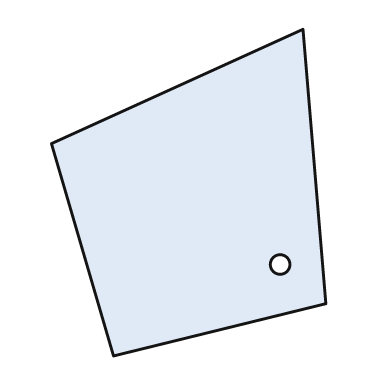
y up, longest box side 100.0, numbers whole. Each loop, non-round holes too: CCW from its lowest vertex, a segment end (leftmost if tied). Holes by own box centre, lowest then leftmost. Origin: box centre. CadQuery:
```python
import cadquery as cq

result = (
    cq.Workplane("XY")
    .moveTo(-23.0, -50.0)
    .lineTo(42.0, -34.0)
    .lineTo(35.0, 50.0)
    .lineTo(-42.0, 15.0)
    .close()
    .moveTo(28.0, -22.0)
    .circle(3.0)
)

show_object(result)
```